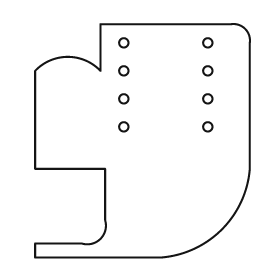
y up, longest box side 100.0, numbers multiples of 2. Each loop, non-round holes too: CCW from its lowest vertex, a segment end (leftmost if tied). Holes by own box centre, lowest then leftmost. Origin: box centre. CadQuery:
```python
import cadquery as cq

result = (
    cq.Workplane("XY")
    .moveTo(-46.0, -50.0)
    .lineTo(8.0, -50.0)
    .threePointArc((34.0, -38.0), (46.0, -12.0))
    .lineTo(46.0, 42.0)
    .threePointArc((44.0, 48.0), (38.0, 50.0))
    .lineTo(-18.0, 50.0)
    .lineTo(-18.0, 30.0)
    .threePointArc((-32.0, 36.0), (-46.0, 30.0))
    .lineTo(-46.0, -12.0)
    .lineTo(-16.0, -12.0)
    .lineTo(-16.0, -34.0)
    .threePointArc((-18.0, -42.0), (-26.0, -44.0))
    .lineTo(-46.0, -44.0)
    .close()
    .moveTo(-8.0, 6.0)
    .circle(2.0)
    .moveTo(28.0, 6.0)
    .circle(2.0)
    .moveTo(-8.0, 18.0)
    .circle(2.0)
    .moveTo(28.0, 18.0)
    .circle(2.0)
    .moveTo(-8.0, 30.0)
    .circle(2.0)
    .moveTo(28.0, 30.0)
    .circle(2.0)
    .moveTo(-8.0, 42.0)
    .circle(2.0)
    .moveTo(28.0, 42.0)
    .circle(2.0)
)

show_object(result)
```